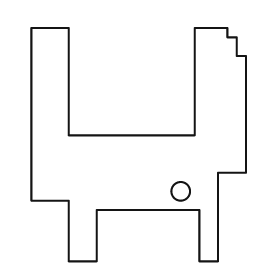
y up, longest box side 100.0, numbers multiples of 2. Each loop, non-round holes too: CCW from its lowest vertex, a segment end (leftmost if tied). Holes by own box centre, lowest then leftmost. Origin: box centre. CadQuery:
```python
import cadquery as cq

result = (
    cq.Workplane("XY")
    .moveTo(-30.0, -50.0)
    .lineTo(-18.0, -50.0)
    .lineTo(-18.0, -28.0)
    .lineTo(26.0, -28.0)
    .lineTo(26.0, -50.0)
    .lineTo(34.0, -50.0)
    .lineTo(34.0, -12.0)
    .lineTo(46.0, -12.0)
    .lineTo(46.0, 38.0)
    .lineTo(42.0, 38.0)
    .lineTo(42.0, 46.0)
    .lineTo(38.0, 46.0)
    .lineTo(38.0, 50.0)
    .lineTo(24.0, 50.0)
    .lineTo(24.0, 4.0)
    .lineTo(-30.0, 4.0)
    .lineTo(-30.0, 50.0)
    .lineTo(-46.0, 50.0)
    .lineTo(-46.0, -24.0)
    .lineTo(-30.0, -24.0)
    .close()
    .moveTo(18.0, -20.0)
    .circle(4.0)
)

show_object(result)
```